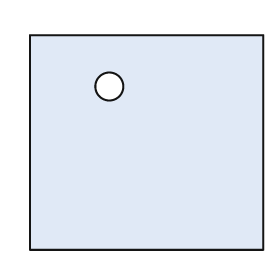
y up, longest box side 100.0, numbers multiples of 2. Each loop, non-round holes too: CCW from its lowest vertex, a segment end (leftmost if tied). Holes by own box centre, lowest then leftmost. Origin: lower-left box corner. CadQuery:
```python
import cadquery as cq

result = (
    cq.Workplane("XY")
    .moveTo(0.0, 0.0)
    .lineTo(100.0, 0.0)
    .lineTo(100.0, 92.0)
    .lineTo(0.0, 92.0)
    .close()
    .moveTo(34.0, 70.0)
    .circle(6.0)
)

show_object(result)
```